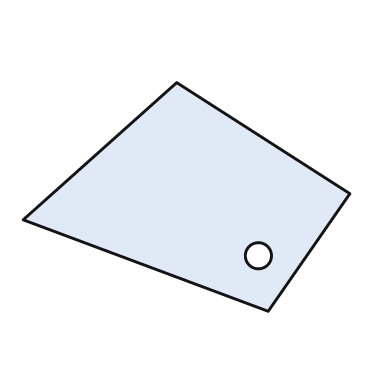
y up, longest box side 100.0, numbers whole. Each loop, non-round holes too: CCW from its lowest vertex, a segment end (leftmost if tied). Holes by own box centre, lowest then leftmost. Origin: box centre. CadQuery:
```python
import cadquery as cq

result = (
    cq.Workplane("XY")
    .moveTo(25.0, -35.0)
    .lineTo(50.0, 1.0)
    .lineTo(-3.0, 35.0)
    .lineTo(-50.0, -7.0)
    .close()
    .moveTo(22.0, -18.0)
    .circle(4.0)
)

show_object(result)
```